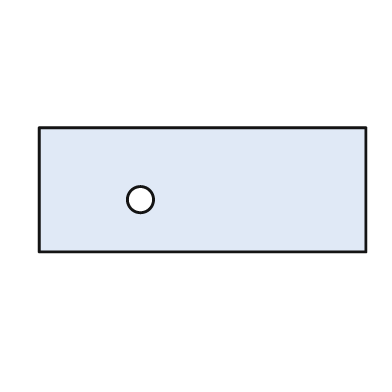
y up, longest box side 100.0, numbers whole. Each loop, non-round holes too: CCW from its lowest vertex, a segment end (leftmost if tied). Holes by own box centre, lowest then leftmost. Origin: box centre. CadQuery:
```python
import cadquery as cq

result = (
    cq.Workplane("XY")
    .moveTo(-50.0, -19.0)
    .lineTo(50.0, -19.0)
    .lineTo(50.0, 19.0)
    .lineTo(-50.0, 19.0)
    .close()
    .moveTo(-19.0, -3.0)
    .circle(4.0)
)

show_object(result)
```